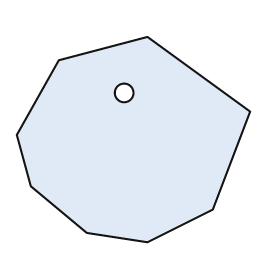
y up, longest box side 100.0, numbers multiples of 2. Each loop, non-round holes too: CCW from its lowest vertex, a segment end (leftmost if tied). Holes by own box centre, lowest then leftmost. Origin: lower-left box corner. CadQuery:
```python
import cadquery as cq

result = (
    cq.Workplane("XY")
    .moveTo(56.0, 0.0)
    .lineTo(84.0, 14.0)
    .lineTo(100.0, 56.0)
    .lineTo(56.0, 88.0)
    .lineTo(18.0, 78.0)
    .lineTo(0.0, 46.0)
    .lineTo(6.0, 24.0)
    .lineTo(30.0, 4.0)
    .close()
    .moveTo(46.0, 64.0)
    .circle(4.0)
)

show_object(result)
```